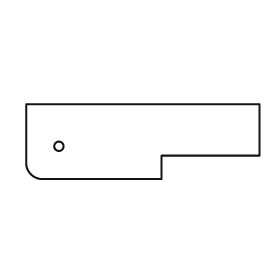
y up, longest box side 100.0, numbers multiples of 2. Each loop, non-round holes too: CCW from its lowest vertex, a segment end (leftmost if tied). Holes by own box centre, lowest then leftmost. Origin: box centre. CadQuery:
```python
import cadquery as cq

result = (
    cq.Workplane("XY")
    .moveTo(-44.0, -16.0)
    .lineTo(8.0, -16.0)
    .lineTo(8.0, -6.0)
    .lineTo(50.0, -6.0)
    .lineTo(50.0, 16.0)
    .lineTo(-50.0, 16.0)
    .lineTo(-50.0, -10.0)
    .threePointArc((-48.0, -14.0), (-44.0, -16.0))
    .close()
    .moveTo(-36.0, -2.0)
    .circle(2.0)
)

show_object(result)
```